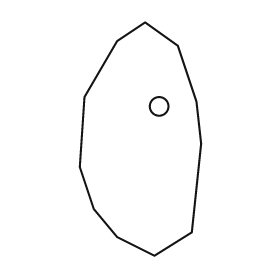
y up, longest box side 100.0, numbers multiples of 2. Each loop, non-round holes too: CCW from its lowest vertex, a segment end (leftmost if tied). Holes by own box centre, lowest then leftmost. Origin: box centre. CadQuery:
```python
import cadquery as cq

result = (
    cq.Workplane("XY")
    .moveTo(6.0, -50.0)
    .lineTo(22.0, -40.0)
    .lineTo(26.0, -2.0)
    .lineTo(24.0, 16.0)
    .lineTo(16.0, 40.0)
    .lineTo(2.0, 50.0)
    .lineTo(-10.0, 42.0)
    .lineTo(-24.0, 18.0)
    .lineTo(-26.0, -12.0)
    .lineTo(-20.0, -30.0)
    .lineTo(-10.0, -42.0)
    .close()
    .moveTo(8.0, 14.0)
    .circle(4.0)
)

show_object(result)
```